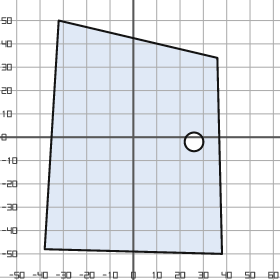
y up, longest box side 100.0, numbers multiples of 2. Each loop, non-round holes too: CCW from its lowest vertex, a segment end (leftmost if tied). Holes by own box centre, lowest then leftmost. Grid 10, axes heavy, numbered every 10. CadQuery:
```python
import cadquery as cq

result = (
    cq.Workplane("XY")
    .moveTo(38.0, -50.0)
    .lineTo(36.0, 34.0)
    .lineTo(-32.0, 50.0)
    .lineTo(-38.0, -48.0)
    .close()
    .moveTo(26.0, -2.0)
    .circle(4.0)
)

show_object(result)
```